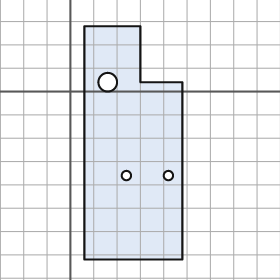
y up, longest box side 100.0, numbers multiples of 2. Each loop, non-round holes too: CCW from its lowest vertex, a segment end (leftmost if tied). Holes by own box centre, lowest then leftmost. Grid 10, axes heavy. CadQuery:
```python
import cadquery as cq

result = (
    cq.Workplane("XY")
    .moveTo(6.0, -72.0)
    .lineTo(48.0, -72.0)
    .lineTo(48.0, 4.0)
    .lineTo(30.0, 4.0)
    .lineTo(30.0, 28.0)
    .lineTo(6.0, 28.0)
    .close()
    .moveTo(24.0, -36.0)
    .circle(2.0)
    .moveTo(42.0, -36.0)
    .circle(2.0)
    .moveTo(16.0, 4.0)
    .circle(4.0)
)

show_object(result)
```